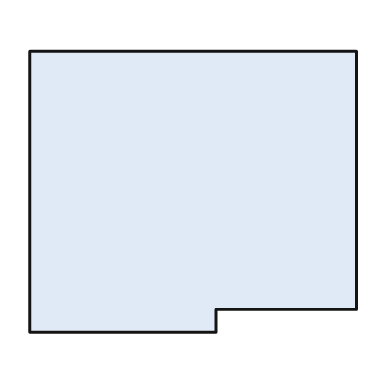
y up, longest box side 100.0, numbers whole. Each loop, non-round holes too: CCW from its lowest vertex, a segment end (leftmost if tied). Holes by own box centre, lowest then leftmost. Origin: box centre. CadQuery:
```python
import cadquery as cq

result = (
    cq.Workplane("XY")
    .moveTo(-50.0, -43.0)
    .lineTo(7.0, -43.0)
    .lineTo(7.0, -36.0)
    .lineTo(50.0, -36.0)
    .lineTo(50.0, 43.0)
    .lineTo(-50.0, 43.0)
    .close()
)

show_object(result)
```